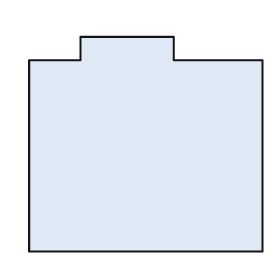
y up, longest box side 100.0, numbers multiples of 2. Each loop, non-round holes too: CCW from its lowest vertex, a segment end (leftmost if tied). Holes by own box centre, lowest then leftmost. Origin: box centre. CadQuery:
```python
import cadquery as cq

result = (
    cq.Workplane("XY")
    .moveTo(-50.0, -46.0)
    .lineTo(50.0, -46.0)
    .lineTo(50.0, 36.0)
    .lineTo(12.0, 36.0)
    .lineTo(12.0, 46.0)
    .lineTo(-28.0, 46.0)
    .lineTo(-28.0, 36.0)
    .lineTo(-50.0, 36.0)
    .close()
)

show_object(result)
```